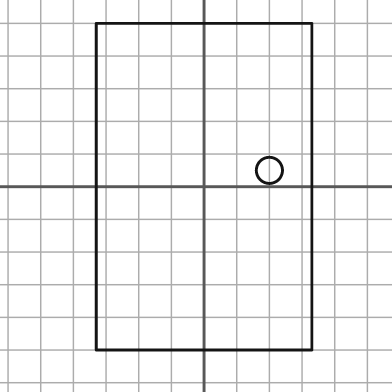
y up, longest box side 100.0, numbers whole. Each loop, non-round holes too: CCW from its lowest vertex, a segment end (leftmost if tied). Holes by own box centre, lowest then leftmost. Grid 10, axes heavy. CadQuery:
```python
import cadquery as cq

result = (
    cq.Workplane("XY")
    .moveTo(-33.0, -50.0)
    .lineTo(33.0, -50.0)
    .lineTo(33.0, 50.0)
    .lineTo(-33.0, 50.0)
    .close()
    .moveTo(20.0, 5.0)
    .circle(4.0)
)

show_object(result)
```